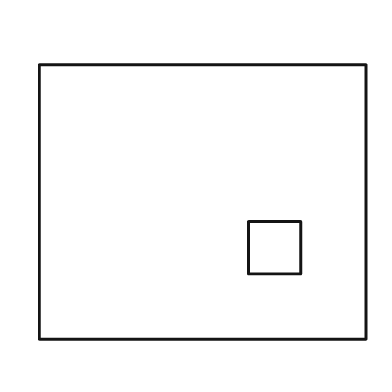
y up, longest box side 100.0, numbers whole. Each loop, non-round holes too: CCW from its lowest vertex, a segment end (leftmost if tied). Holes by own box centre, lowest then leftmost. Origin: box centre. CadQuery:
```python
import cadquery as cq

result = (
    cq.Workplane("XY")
    .moveTo(-50.0, -42.0)
    .lineTo(50.0, -42.0)
    .lineTo(50.0, 42.0)
    .lineTo(-50.0, 42.0)
    .close()
    .moveTo(14.0, -22.0)
    .lineTo(30.0, -22.0)
    .lineTo(30.0, -6.0)
    .lineTo(14.0, -6.0)
    .close()
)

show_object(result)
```